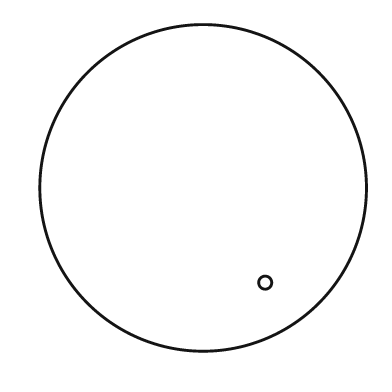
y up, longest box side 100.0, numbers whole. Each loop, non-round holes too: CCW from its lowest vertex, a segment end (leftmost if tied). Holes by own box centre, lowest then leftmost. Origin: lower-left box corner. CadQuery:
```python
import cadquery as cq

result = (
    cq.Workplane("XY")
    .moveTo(50.0, 50.0)
    .circle(50.0)
    .moveTo(69.0, 21.0)
    .circle(2.0)
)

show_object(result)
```